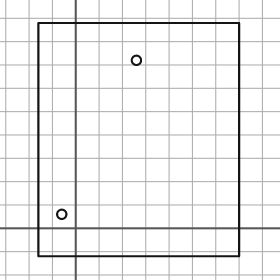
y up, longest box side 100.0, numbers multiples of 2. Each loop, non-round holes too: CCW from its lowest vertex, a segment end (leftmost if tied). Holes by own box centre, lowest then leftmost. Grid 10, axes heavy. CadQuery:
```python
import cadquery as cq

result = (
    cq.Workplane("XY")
    .moveTo(-16.0, -12.0)
    .lineTo(70.0, -12.0)
    .lineTo(70.0, 88.0)
    .lineTo(-16.0, 88.0)
    .close()
    .moveTo(-6.0, 6.0)
    .circle(2.0)
    .moveTo(26.0, 72.0)
    .circle(2.0)
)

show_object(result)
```